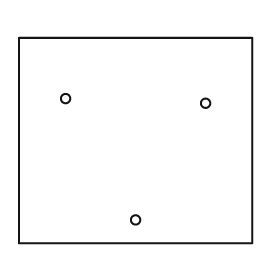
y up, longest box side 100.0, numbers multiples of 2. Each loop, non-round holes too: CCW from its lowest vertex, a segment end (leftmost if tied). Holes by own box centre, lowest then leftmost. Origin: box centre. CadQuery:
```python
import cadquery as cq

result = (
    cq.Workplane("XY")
    .moveTo(-50.0, -44.0)
    .lineTo(50.0, -44.0)
    .lineTo(50.0, 44.0)
    .lineTo(-50.0, 44.0)
    .close()
    .moveTo(0.0, -34.0)
    .circle(2.0)
    .moveTo(30.0, 16.0)
    .circle(2.0)
    .moveTo(-30.0, 18.0)
    .circle(2.0)
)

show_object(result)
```